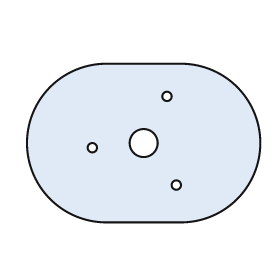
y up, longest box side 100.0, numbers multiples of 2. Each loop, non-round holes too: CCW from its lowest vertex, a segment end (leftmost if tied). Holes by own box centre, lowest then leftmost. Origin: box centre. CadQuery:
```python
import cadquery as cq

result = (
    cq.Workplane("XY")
    .moveTo(-16.0, -34.0)
    .lineTo(16.0, -34.0)
    .threePointArc((50.0, 0.0), (16.0, 34.0))
    .lineTo(-16.0, 34.0)
    .threePointArc((-50.0, 0.0), (-16.0, -34.0))
    .close()
    .moveTo(14.0, -18.0)
    .circle(2.0)
    .moveTo(-22.0, -2.0)
    .circle(2.0)
    .moveTo(0.0, 0.0)
    .circle(6.0)
    .moveTo(10.0, 20.0)
    .circle(2.0)
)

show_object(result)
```